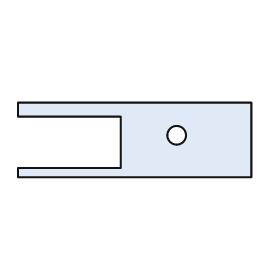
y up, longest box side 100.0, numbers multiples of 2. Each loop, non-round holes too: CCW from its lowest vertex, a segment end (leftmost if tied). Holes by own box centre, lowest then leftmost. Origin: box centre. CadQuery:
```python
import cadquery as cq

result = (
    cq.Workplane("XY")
    .moveTo(-50.0, -16.0)
    .lineTo(50.0, -16.0)
    .lineTo(50.0, 16.0)
    .lineTo(-50.0, 16.0)
    .lineTo(-50.0, 10.0)
    .lineTo(-6.0, 10.0)
    .lineTo(-6.0, -12.0)
    .lineTo(-50.0, -12.0)
    .close()
    .moveTo(18.0, 2.0)
    .circle(4.0)
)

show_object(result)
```